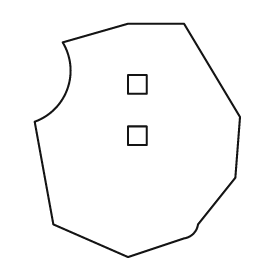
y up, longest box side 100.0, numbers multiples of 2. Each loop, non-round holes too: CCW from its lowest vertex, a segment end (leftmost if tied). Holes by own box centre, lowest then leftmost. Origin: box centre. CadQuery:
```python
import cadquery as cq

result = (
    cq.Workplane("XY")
    .moveTo(-4.0, -50.0)
    .lineTo(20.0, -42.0)
    .threePointArc((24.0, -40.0), (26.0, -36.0))
    .lineTo(42.0, -16.0)
    .lineTo(44.0, 10.0)
    .lineTo(20.0, 50.0)
    .lineTo(-4.0, 50.0)
    .lineTo(-32.0, 42.0)
    .threePointArc((-30.0, 22.0), (-44.0, 8.0))
    .lineTo(-36.0, -36.0)
    .close()
    .moveTo(-4.0, -2.0)
    .lineTo(4.0, -2.0)
    .lineTo(4.0, 6.0)
    .lineTo(-4.0, 6.0)
    .close()
    .moveTo(-4.0, 20.0)
    .lineTo(4.0, 20.0)
    .lineTo(4.0, 28.0)
    .lineTo(-4.0, 28.0)
    .close()
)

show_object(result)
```